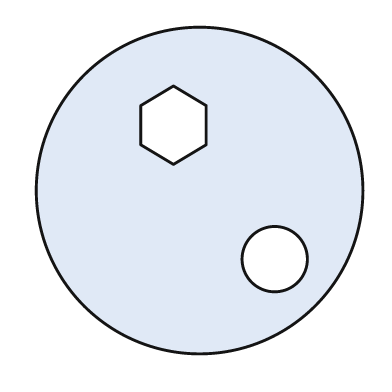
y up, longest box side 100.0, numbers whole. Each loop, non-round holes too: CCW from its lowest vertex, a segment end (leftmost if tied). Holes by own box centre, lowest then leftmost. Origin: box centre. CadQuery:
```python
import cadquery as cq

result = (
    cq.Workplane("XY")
    .moveTo(0.0, 0.0)
    .circle(50.0)
    .moveTo(23.0, -21.0)
    .circle(10.0)
    .moveTo(-8.0, 8.0)
    .lineTo(2.0, 14.0)
    .lineTo(2.0, 26.0)
    .lineTo(-8.0, 32.0)
    .lineTo(-18.0, 26.0)
    .lineTo(-18.0, 14.0)
    .close()
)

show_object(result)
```